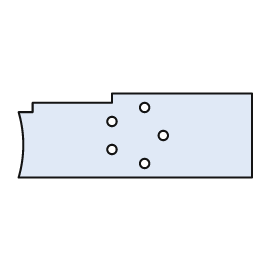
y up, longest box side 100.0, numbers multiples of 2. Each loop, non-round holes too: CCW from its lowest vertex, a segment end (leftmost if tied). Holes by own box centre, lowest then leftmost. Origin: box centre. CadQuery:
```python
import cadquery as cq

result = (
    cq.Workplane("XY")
    .moveTo(-50.0, -18.0)
    .lineTo(50.0, -18.0)
    .lineTo(50.0, 18.0)
    .lineTo(-10.0, 18.0)
    .lineTo(-10.0, 14.0)
    .lineTo(-44.0, 14.0)
    .lineTo(-44.0, 10.0)
    .lineTo(-50.0, 10.0)
    .threePointArc((-48.0, -4.0), (-50.0, -18.0))
    .close()
    .moveTo(4.0, -12.0)
    .circle(2.0)
    .moveTo(-10.0, -6.0)
    .circle(2.0)
    .moveTo(12.0, 0.0)
    .circle(2.0)
    .moveTo(-10.0, 6.0)
    .circle(2.0)
    .moveTo(4.0, 12.0)
    .circle(2.0)
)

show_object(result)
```